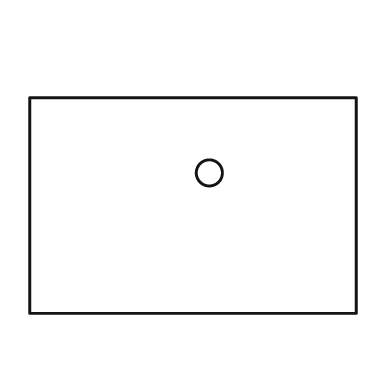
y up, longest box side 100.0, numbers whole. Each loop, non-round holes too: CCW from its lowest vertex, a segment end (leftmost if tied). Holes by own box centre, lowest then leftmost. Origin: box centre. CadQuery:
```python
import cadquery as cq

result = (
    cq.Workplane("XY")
    .moveTo(-50.0, -33.0)
    .lineTo(50.0, -33.0)
    .lineTo(50.0, 33.0)
    .lineTo(-50.0, 33.0)
    .close()
    .moveTo(5.0, 10.0)
    .circle(4.0)
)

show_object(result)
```